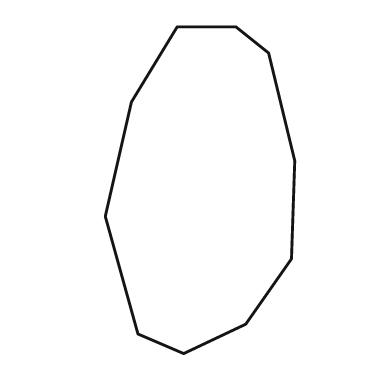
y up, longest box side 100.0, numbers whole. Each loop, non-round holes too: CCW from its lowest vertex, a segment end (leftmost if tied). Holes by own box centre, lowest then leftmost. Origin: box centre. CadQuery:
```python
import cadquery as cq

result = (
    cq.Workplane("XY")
    .moveTo(-5.0, -50.0)
    .lineTo(14.0, -41.0)
    .lineTo(28.0, -21.0)
    .lineTo(29.0, 9.0)
    .lineTo(21.0, 42.0)
    .lineTo(11.0, 50.0)
    .lineTo(-7.0, 50.0)
    .lineTo(-21.0, 27.0)
    .lineTo(-29.0, -8.0)
    .lineTo(-19.0, -44.0)
    .close()
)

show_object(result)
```